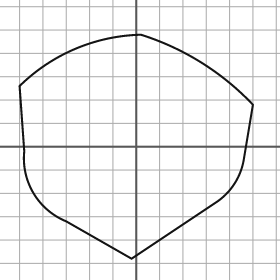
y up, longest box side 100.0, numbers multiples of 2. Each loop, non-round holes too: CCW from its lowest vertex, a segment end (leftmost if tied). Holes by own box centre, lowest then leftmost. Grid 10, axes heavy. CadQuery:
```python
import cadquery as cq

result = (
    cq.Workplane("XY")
    .moveTo(-2.0, -48.0)
    .lineTo(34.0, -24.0)
    .threePointArc((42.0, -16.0), (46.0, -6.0))
    .lineTo(50.0, 18.0)
    .threePointArc((28.0, 36.0), (2.0, 48.0))
    .threePointArc((-26.0, 42.0), (-50.0, 26.0))
    .lineTo(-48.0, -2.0)
    .threePointArc((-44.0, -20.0), (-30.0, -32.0))
    .close()
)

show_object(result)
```